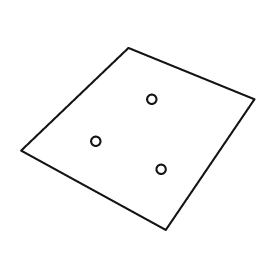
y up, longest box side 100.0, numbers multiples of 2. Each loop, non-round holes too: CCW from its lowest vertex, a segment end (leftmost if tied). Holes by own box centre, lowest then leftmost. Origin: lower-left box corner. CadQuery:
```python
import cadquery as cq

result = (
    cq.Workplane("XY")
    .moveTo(62.0, 0.0)
    .lineTo(100.0, 56.0)
    .lineTo(46.0, 78.0)
    .lineTo(0.0, 34.0)
    .close()
    .moveTo(60.0, 26.0)
    .circle(2.0)
    .moveTo(32.0, 38.0)
    .circle(2.0)
    .moveTo(56.0, 56.0)
    .circle(2.0)
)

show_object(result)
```